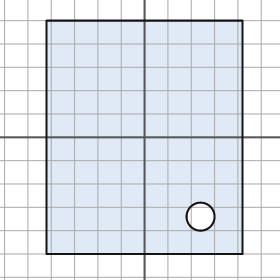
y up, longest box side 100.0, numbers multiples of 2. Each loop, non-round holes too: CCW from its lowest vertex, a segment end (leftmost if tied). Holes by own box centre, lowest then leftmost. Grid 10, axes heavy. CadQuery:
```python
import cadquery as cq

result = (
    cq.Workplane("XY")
    .moveTo(-42.0, -50.0)
    .lineTo(42.0, -50.0)
    .lineTo(42.0, 50.0)
    .lineTo(-42.0, 50.0)
    .close()
    .moveTo(24.0, -34.0)
    .circle(6.0)
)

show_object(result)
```